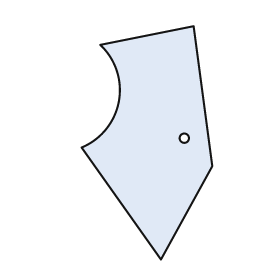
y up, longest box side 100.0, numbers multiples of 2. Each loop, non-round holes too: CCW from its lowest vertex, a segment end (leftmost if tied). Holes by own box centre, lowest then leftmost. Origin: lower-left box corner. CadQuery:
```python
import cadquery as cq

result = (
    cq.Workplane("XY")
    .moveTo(34.0, 0.0)
    .lineTo(56.0, 40.0)
    .lineTo(48.0, 100.0)
    .lineTo(8.0, 92.0)
    .threePointArc((16.0, 68.0), (0.0, 48.0))
    .close()
    .moveTo(44.0, 52.0)
    .circle(2.0)
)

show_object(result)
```